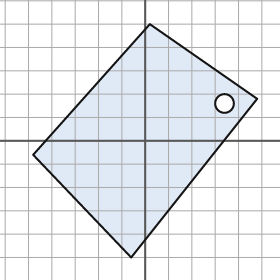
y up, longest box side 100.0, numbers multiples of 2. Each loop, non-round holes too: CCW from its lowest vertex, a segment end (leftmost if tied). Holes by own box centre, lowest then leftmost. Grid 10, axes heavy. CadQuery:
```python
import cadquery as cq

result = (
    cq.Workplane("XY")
    .moveTo(-6.0, -50.0)
    .lineTo(48.0, 18.0)
    .lineTo(2.0, 50.0)
    .lineTo(-48.0, -6.0)
    .close()
    .moveTo(34.0, 16.0)
    .circle(4.0)
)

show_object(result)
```